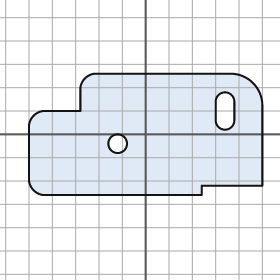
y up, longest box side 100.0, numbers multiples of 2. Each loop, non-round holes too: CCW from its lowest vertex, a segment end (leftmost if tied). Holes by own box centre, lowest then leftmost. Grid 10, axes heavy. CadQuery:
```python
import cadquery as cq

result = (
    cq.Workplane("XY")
    .moveTo(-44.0, -26.0)
    .lineTo(24.0, -26.0)
    .lineTo(24.0, -22.0)
    .lineTo(50.0, -22.0)
    .lineTo(50.0, 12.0)
    .threePointArc((46.0, 22.0), (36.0, 26.0))
    .lineTo(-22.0, 26.0)
    .threePointArc((-26.0, 24.0), (-28.0, 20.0))
    .lineTo(-28.0, 10.0)
    .lineTo(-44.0, 10.0)
    .threePointArc((-48.0, 8.0), (-50.0, 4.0))
    .lineTo(-50.0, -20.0)
    .threePointArc((-48.0, -24.0), (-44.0, -26.0))
    .close()
    .moveTo(-12.0, -4.0)
    .circle(4.0)
    .moveTo(30.0, 6.0)
    .threePointArc((34.0, 2.0), (38.0, 6.0))
    .lineTo(38.0, 14.0)
    .threePointArc((34.0, 18.0), (30.0, 14.0))
    .close()
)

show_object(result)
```